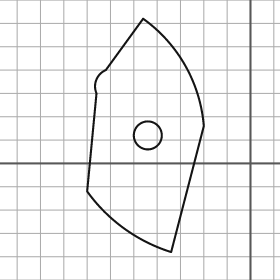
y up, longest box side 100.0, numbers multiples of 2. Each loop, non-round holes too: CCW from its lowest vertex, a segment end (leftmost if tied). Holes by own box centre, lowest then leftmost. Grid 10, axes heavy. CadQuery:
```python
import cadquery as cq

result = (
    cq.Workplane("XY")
    .moveTo(-34.0, -38.0)
    .lineTo(-20.0, 16.0)
    .threePointArc((-28.0, 42.0), (-46.0, 62.0))
    .lineTo(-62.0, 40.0)
    .threePointArc((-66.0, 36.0), (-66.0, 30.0))
    .lineTo(-70.0, -12.0)
    .threePointArc((-54.0, -28.0), (-34.0, -38.0))
    .close()
    .moveTo(-44.0, 12.0)
    .circle(6.0)
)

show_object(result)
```